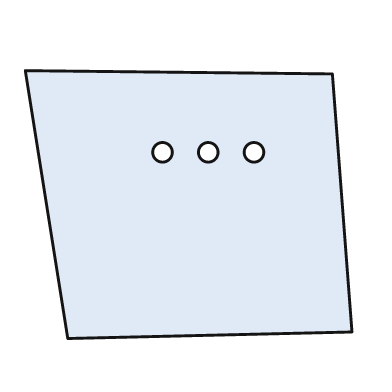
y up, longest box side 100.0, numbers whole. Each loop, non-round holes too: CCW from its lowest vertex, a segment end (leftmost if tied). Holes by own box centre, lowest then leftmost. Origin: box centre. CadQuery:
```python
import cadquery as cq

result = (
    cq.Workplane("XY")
    .moveTo(-37.0, -41.0)
    .lineTo(50.0, -39.0)
    .lineTo(44.0, 40.0)
    .lineTo(-50.0, 41.0)
    .close()
    .moveTo(-8.0, 16.0)
    .circle(3.0)
    .moveTo(6.0, 16.0)
    .circle(3.0)
    .moveTo(20.0, 16.0)
    .circle(3.0)
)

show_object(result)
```